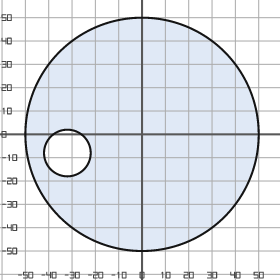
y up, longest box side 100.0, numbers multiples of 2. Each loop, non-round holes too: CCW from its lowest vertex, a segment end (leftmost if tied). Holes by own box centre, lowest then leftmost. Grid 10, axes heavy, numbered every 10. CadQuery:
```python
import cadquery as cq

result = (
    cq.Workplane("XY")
    .moveTo(0.0, 0.0)
    .circle(50.0)
    .moveTo(-32.0, -8.0)
    .circle(10.0)
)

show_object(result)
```